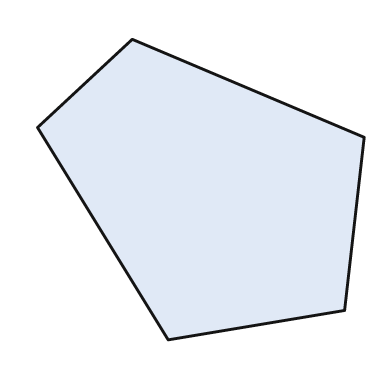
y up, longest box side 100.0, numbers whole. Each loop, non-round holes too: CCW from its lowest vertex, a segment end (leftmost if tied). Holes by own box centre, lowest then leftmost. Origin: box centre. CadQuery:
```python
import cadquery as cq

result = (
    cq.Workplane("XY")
    .moveTo(-10.0, -46.0)
    .lineTo(44.0, -37.0)
    .lineTo(50.0, 16.0)
    .lineTo(-21.0, 46.0)
    .lineTo(-50.0, 19.0)
    .close()
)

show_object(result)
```